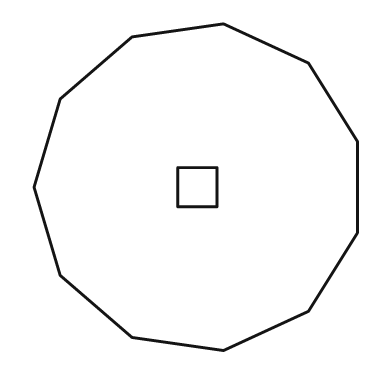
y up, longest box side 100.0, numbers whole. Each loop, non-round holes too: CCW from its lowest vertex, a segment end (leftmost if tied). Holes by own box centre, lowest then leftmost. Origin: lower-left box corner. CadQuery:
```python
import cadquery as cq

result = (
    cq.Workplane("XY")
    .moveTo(58.0, 0.0)
    .lineTo(84.0, 12.0)
    .lineTo(99.0, 36.0)
    .lineTo(99.0, 64.0)
    .lineTo(84.0, 88.0)
    .lineTo(58.0, 100.0)
    .lineTo(30.0, 96.0)
    .lineTo(8.0, 77.0)
    .lineTo(0.0, 50.0)
    .lineTo(8.0, 23.0)
    .lineTo(30.0, 4.0)
    .close()
    .moveTo(44.0, 44.0)
    .lineTo(56.0, 44.0)
    .lineTo(56.0, 56.0)
    .lineTo(44.0, 56.0)
    .close()
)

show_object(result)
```